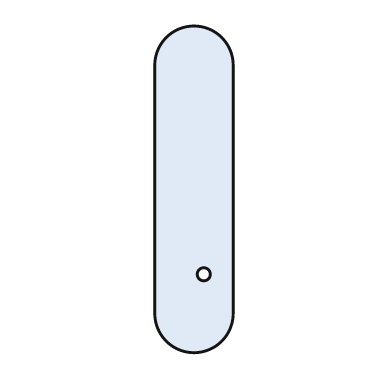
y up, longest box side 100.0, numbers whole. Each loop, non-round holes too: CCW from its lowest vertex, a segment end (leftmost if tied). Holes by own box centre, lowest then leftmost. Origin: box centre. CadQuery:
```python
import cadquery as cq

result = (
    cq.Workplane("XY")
    .moveTo(-12.0, -38.0)
    .threePointArc((0.0, -50.0), (12.0, -38.0))
    .lineTo(12.0, 38.0)
    .threePointArc((0.0, 50.0), (-12.0, 38.0))
    .close()
    .moveTo(3.0, -26.0)
    .circle(2.0)
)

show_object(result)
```